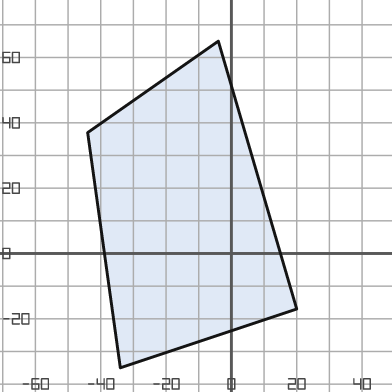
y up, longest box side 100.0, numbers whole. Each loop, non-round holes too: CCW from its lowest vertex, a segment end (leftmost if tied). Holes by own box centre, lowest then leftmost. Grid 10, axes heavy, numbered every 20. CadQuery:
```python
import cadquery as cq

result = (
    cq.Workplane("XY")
    .moveTo(-34.0, -35.0)
    .lineTo(20.0, -17.0)
    .lineTo(-4.0, 65.0)
    .lineTo(-44.0, 37.0)
    .close()
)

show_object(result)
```